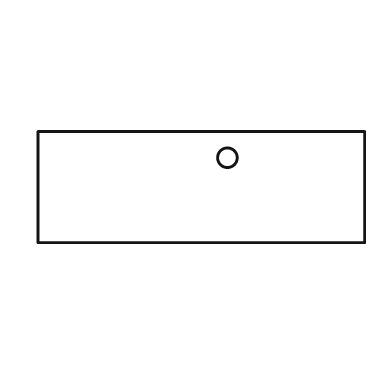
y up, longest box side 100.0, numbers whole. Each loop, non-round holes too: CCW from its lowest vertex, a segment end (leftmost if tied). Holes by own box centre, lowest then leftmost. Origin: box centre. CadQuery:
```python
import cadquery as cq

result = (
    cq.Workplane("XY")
    .moveTo(-50.0, -17.0)
    .lineTo(50.0, -17.0)
    .lineTo(50.0, 17.0)
    .lineTo(-50.0, 17.0)
    .close()
    .moveTo(8.0, 9.0)
    .circle(3.0)
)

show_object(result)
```